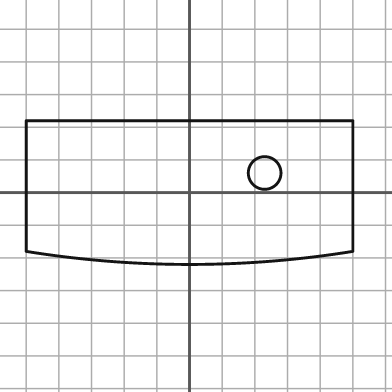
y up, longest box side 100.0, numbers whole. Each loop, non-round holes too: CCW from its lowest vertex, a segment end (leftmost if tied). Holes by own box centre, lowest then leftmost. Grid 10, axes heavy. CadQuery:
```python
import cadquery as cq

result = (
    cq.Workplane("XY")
    .moveTo(-50.0, -18.0)
    .threePointArc((0.0, -22.0), (50.0, -18.0))
    .lineTo(50.0, 22.0)
    .lineTo(-50.0, 22.0)
    .close()
    .moveTo(23.0, 6.0)
    .circle(5.0)
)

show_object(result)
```